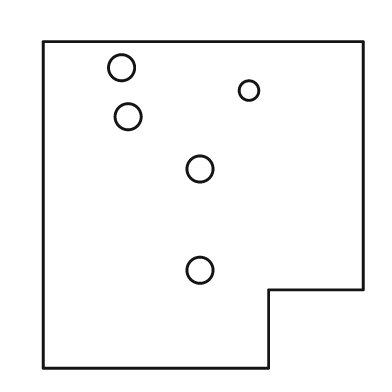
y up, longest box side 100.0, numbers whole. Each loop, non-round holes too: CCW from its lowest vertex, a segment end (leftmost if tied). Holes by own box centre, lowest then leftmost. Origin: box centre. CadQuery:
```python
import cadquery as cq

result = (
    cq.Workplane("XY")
    .moveTo(-49.0, -50.0)
    .lineTo(20.0, -50.0)
    .lineTo(20.0, -26.0)
    .lineTo(49.0, -26.0)
    .lineTo(49.0, 50.0)
    .lineTo(-49.0, 50.0)
    .close()
    .moveTo(-1.0, -20.0)
    .circle(4.0)
    .moveTo(-1.0, 11.0)
    .circle(4.0)
    .moveTo(-23.0, 27.0)
    .circle(4.0)
    .moveTo(14.0, 35.0)
    .circle(3.0)
    .moveTo(-25.0, 42.0)
    .circle(4.0)
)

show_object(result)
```